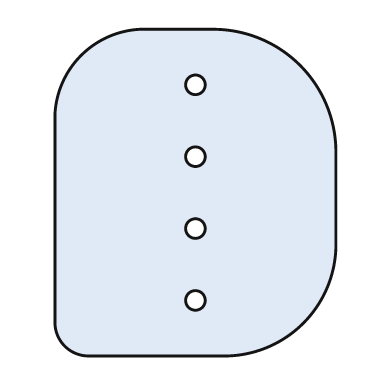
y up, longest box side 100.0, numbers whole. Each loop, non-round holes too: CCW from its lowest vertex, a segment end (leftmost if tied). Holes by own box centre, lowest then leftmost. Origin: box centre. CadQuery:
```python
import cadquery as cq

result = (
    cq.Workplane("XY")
    .moveTo(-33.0, -50.0)
    .lineTo(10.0, -50.0)
    .threePointArc((33.0, -40.0), (43.0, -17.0))
    .lineTo(43.0, 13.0)
    .threePointArc((32.0, 39.0), (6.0, 50.0))
    .lineTo(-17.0, 50.0)
    .threePointArc((-35.0, 42.0), (-43.0, 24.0))
    .lineTo(-43.0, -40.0)
    .threePointArc((-40.0, -47.0), (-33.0, -50.0))
    .close()
    .moveTo(0.0, -33.0)
    .circle(3.0)
    .moveTo(0.0, -11.0)
    .circle(3.0)
    .moveTo(0.0, 11.0)
    .circle(3.0)
    .moveTo(0.0, 33.0)
    .circle(3.0)
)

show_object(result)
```